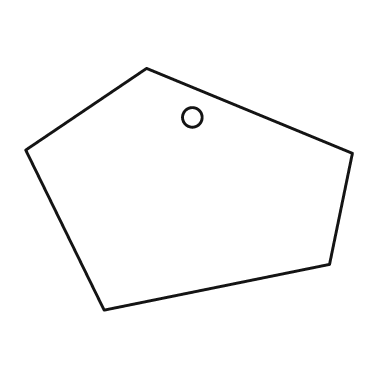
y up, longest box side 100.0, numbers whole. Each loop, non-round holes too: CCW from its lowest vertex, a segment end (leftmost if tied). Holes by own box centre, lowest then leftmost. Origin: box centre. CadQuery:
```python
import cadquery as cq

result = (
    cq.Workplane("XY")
    .moveTo(-26.0, -37.0)
    .lineTo(43.0, -23.0)
    .lineTo(50.0, 11.0)
    .lineTo(-13.0, 37.0)
    .lineTo(-50.0, 12.0)
    .close()
    .moveTo(1.0, 22.0)
    .circle(3.0)
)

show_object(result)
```